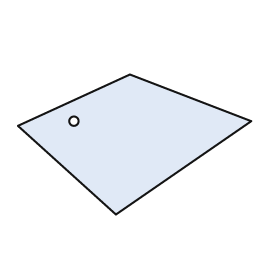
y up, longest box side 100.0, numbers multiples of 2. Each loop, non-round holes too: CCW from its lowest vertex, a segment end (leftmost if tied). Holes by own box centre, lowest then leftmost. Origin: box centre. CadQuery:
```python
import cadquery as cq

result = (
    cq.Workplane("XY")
    .moveTo(-8.0, -30.0)
    .lineTo(50.0, 10.0)
    .lineTo(-2.0, 30.0)
    .lineTo(-50.0, 8.0)
    .close()
    .moveTo(-26.0, 10.0)
    .circle(2.0)
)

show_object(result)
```